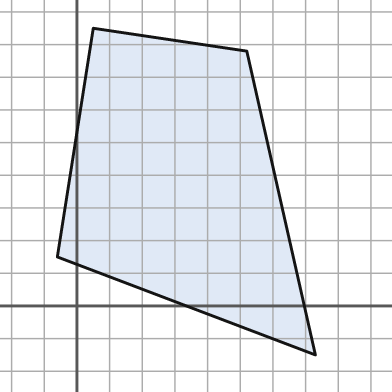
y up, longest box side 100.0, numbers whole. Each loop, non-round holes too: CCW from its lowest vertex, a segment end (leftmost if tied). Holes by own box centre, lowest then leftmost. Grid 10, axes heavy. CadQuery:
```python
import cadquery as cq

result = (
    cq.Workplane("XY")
    .moveTo(73.0, -15.0)
    .lineTo(52.0, 78.0)
    .lineTo(5.0, 85.0)
    .lineTo(-6.0, 15.0)
    .close()
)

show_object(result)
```